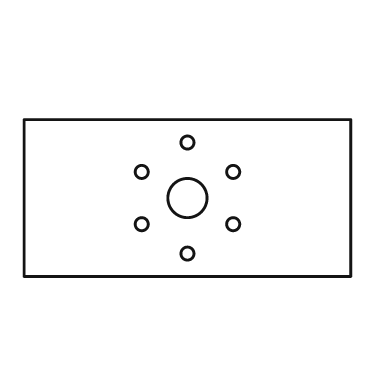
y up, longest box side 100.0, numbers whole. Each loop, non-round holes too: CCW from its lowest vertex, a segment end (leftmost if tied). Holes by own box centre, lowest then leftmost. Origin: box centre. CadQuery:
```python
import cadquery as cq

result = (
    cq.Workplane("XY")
    .moveTo(-50.0, -24.0)
    .lineTo(50.0, -24.0)
    .lineTo(50.0, 24.0)
    .lineTo(-50.0, 24.0)
    .close()
    .moveTo(0.0, -17.0)
    .circle(2.0)
    .moveTo(-14.0, -8.0)
    .circle(2.0)
    .moveTo(14.0, -8.0)
    .circle(2.0)
    .moveTo(0.0, 0.0)
    .circle(6.0)
    .moveTo(-14.0, 8.0)
    .circle(2.0)
    .moveTo(14.0, 8.0)
    .circle(2.0)
    .moveTo(0.0, 17.0)
    .circle(2.0)
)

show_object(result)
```